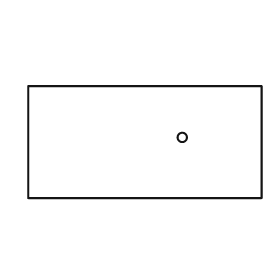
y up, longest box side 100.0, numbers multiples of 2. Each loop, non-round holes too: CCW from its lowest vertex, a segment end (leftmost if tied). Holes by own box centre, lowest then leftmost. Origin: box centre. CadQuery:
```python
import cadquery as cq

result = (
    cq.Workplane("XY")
    .moveTo(-50.0, -24.0)
    .lineTo(50.0, -24.0)
    .lineTo(50.0, 24.0)
    .lineTo(-50.0, 24.0)
    .close()
    .moveTo(16.0, 2.0)
    .circle(2.0)
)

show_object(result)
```